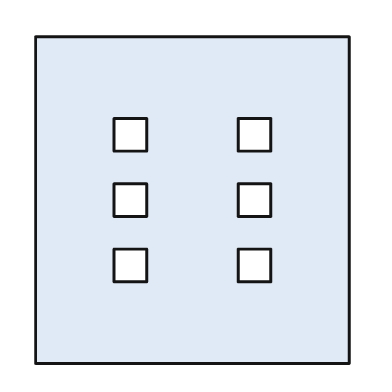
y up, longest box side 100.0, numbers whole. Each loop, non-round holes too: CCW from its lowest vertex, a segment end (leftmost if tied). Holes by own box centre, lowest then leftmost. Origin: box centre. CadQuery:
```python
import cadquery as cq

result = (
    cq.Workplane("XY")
    .moveTo(-48.0, -50.0)
    .lineTo(48.0, -50.0)
    .lineTo(48.0, 50.0)
    .lineTo(-48.0, 50.0)
    .close()
    .moveTo(-24.0, -25.0)
    .lineTo(-14.0, -25.0)
    .lineTo(-14.0, -15.0)
    .lineTo(-24.0, -15.0)
    .close()
    .moveTo(14.0, -25.0)
    .lineTo(24.0, -25.0)
    .lineTo(24.0, -15.0)
    .lineTo(14.0, -15.0)
    .close()
    .moveTo(-24.0, -5.0)
    .lineTo(-14.0, -5.0)
    .lineTo(-14.0, 5.0)
    .lineTo(-24.0, 5.0)
    .close()
    .moveTo(14.0, -5.0)
    .lineTo(24.0, -5.0)
    .lineTo(24.0, 5.0)
    .lineTo(14.0, 5.0)
    .close()
    .moveTo(-24.0, 15.0)
    .lineTo(-14.0, 15.0)
    .lineTo(-14.0, 25.0)
    .lineTo(-24.0, 25.0)
    .close()
    .moveTo(14.0, 15.0)
    .lineTo(24.0, 15.0)
    .lineTo(24.0, 25.0)
    .lineTo(14.0, 25.0)
    .close()
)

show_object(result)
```